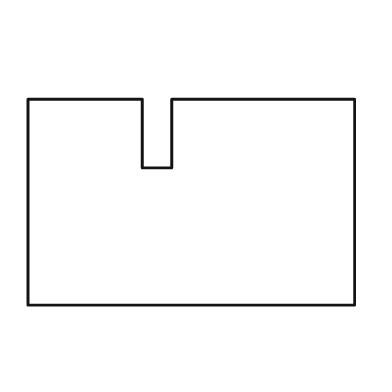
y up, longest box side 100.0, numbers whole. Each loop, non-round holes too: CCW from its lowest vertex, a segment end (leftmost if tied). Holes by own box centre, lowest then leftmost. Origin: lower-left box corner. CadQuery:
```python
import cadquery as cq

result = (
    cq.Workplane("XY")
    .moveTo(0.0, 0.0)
    .lineTo(100.0, 0.0)
    .lineTo(100.0, 63.0)
    .lineTo(44.0, 63.0)
    .lineTo(44.0, 42.0)
    .lineTo(35.0, 42.0)
    .lineTo(35.0, 63.0)
    .lineTo(0.0, 63.0)
    .close()
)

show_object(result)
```